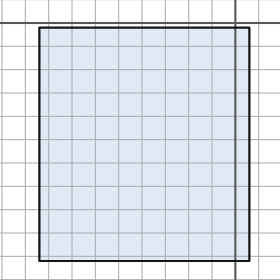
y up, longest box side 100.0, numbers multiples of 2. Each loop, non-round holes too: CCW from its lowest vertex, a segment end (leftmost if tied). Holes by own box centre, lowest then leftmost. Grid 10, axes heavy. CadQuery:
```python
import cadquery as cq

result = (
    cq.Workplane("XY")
    .moveTo(-84.0, -102.0)
    .lineTo(6.0, -102.0)
    .lineTo(6.0, -2.0)
    .lineTo(-84.0, -2.0)
    .close()
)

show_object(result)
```